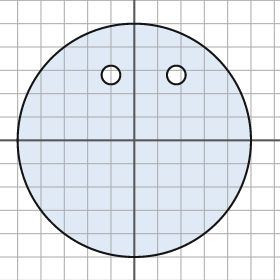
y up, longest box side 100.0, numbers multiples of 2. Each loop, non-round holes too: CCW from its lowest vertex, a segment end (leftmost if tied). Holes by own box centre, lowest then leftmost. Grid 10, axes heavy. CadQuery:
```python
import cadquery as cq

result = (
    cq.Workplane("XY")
    .moveTo(0.0, 0.0)
    .circle(50.0)
    .moveTo(-10.0, 28.0)
    .circle(4.0)
    .moveTo(18.0, 28.0)
    .circle(4.0)
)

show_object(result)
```